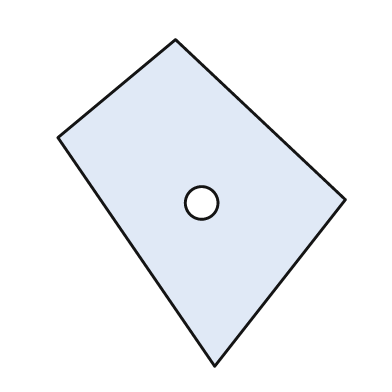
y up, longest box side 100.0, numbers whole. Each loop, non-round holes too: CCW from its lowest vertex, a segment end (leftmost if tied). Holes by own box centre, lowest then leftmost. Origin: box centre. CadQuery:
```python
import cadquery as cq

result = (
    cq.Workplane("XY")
    .moveTo(4.0, -50.0)
    .lineTo(44.0, 1.0)
    .lineTo(-8.0, 50.0)
    .lineTo(-44.0, 20.0)
    .close()
    .moveTo(0.0, 0.0)
    .circle(5.0)
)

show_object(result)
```